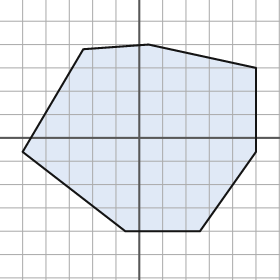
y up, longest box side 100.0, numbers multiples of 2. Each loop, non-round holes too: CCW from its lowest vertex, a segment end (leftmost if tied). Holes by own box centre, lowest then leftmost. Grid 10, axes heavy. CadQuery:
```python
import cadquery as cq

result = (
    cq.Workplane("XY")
    .moveTo(-6.0, -40.0)
    .lineTo(26.0, -40.0)
    .lineTo(50.0, -6.0)
    .lineTo(50.0, 30.0)
    .lineTo(4.0, 40.0)
    .lineTo(-24.0, 38.0)
    .lineTo(-50.0, -6.0)
    .close()
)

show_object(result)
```